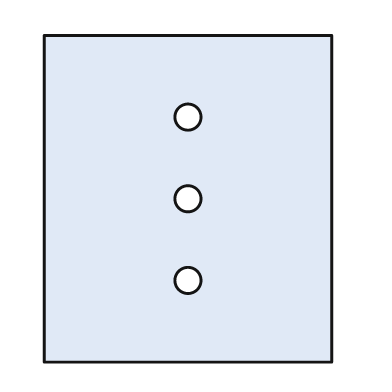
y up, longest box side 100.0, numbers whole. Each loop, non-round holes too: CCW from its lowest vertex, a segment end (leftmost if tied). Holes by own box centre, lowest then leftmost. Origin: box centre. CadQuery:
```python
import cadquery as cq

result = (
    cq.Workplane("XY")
    .moveTo(-44.0, -50.0)
    .lineTo(44.0, -50.0)
    .lineTo(44.0, 50.0)
    .lineTo(-44.0, 50.0)
    .close()
    .moveTo(0.0, -25.0)
    .circle(4.0)
    .moveTo(0.0, 0.0)
    .circle(4.0)
    .moveTo(0.0, 25.0)
    .circle(4.0)
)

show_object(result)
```